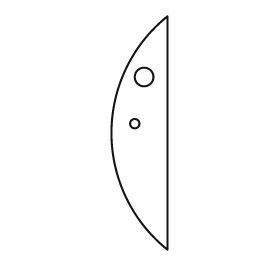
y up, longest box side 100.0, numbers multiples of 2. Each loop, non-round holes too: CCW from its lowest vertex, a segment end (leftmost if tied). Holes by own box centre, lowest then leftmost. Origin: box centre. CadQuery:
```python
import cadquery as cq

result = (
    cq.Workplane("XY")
    .moveTo(12.0, -50.0)
    .lineTo(12.0, 50.0)
    .threePointArc((-12.0, 0.0), (12.0, -50.0))
    .close()
    .moveTo(-2.0, 4.0)
    .circle(2.0)
    .moveTo(2.0, 24.0)
    .circle(4.0)
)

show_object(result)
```